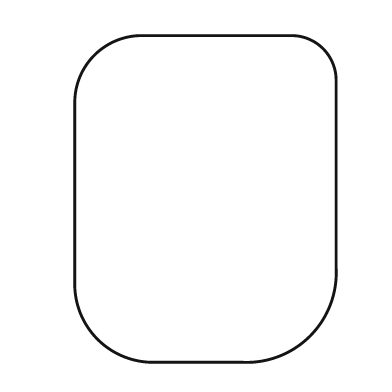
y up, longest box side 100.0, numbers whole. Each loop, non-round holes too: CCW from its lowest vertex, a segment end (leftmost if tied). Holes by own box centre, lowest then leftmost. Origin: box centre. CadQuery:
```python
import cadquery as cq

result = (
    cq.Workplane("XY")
    .moveTo(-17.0, -50.0)
    .lineTo(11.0, -50.0)
    .threePointArc((32.0, -42.0), (40.0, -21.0))
    .lineTo(40.0, 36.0)
    .threePointArc((36.0, 46.0), (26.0, 50.0))
    .lineTo(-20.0, 50.0)
    .threePointArc((-34.0, 44.0), (-40.0, 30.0))
    .lineTo(-40.0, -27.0)
    .threePointArc((-33.0, -43.0), (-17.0, -50.0))
    .close()
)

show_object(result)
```